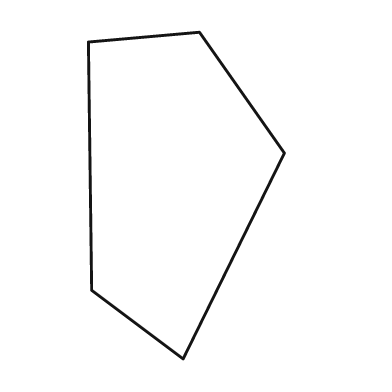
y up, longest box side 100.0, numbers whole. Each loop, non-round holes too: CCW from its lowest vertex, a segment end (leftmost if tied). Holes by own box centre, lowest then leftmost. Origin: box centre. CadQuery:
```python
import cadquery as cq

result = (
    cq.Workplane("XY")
    .moveTo(-1.0, -50.0)
    .lineTo(30.0, 13.0)
    .lineTo(4.0, 50.0)
    .lineTo(-30.0, 47.0)
    .lineTo(-29.0, -29.0)
    .close()
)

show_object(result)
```